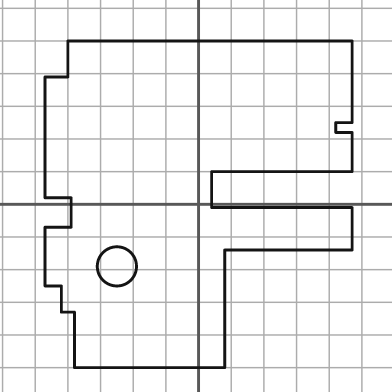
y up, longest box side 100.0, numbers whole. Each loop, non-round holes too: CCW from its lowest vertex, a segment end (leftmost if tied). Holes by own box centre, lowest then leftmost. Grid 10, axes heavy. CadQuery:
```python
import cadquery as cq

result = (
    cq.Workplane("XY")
    .moveTo(-38.0, -50.0)
    .lineTo(8.0, -50.0)
    .lineTo(8.0, -14.0)
    .lineTo(47.0, -14.0)
    .lineTo(47.0, -1.0)
    .lineTo(4.0, -1.0)
    .lineTo(4.0, 10.0)
    .lineTo(47.0, 10.0)
    .lineTo(47.0, 22.0)
    .lineTo(42.0, 22.0)
    .lineTo(42.0, 25.0)
    .lineTo(47.0, 25.0)
    .lineTo(47.0, 50.0)
    .lineTo(-40.0, 50.0)
    .lineTo(-40.0, 39.0)
    .lineTo(-47.0, 39.0)
    .lineTo(-47.0, 2.0)
    .lineTo(-39.0, 2.0)
    .lineTo(-39.0, -7.0)
    .lineTo(-47.0, -7.0)
    .lineTo(-47.0, -25.0)
    .lineTo(-42.0, -25.0)
    .lineTo(-42.0, -33.0)
    .lineTo(-38.0, -33.0)
    .close()
    .moveTo(-25.0, -19.0)
    .circle(6.0)
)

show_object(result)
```